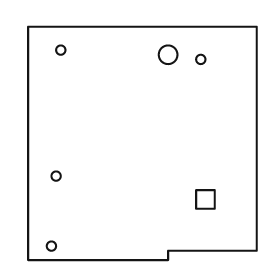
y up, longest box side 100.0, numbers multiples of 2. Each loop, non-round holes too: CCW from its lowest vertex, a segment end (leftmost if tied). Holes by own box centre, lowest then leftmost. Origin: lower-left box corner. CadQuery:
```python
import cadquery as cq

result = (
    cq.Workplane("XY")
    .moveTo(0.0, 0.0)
    .lineTo(60.0, 0.0)
    .lineTo(60.0, 4.0)
    .lineTo(98.0, 4.0)
    .lineTo(98.0, 100.0)
    .lineTo(0.0, 100.0)
    .close()
    .moveTo(10.0, 6.0)
    .circle(2.0)
    .moveTo(72.0, 22.0)
    .lineTo(80.0, 22.0)
    .lineTo(80.0, 30.0)
    .lineTo(72.0, 30.0)
    .close()
    .moveTo(12.0, 36.0)
    .circle(2.0)
    .moveTo(74.0, 86.0)
    .circle(2.0)
    .moveTo(60.0, 88.0)
    .circle(4.0)
    .moveTo(14.0, 90.0)
    .circle(2.0)
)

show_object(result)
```